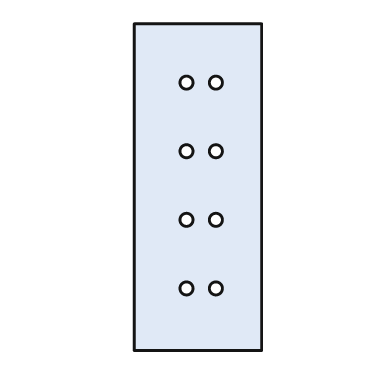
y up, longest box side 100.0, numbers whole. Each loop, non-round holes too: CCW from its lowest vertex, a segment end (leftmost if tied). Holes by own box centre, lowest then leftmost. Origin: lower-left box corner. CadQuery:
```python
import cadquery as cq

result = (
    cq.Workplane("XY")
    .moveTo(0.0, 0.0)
    .lineTo(39.0, 0.0)
    .lineTo(39.0, 100.0)
    .lineTo(0.0, 100.0)
    .close()
    .moveTo(16.0, 19.0)
    .circle(2.0)
    .moveTo(25.0, 19.0)
    .circle(2.0)
    .moveTo(16.0, 40.0)
    .circle(2.0)
    .moveTo(25.0, 40.0)
    .circle(2.0)
    .moveTo(16.0, 61.0)
    .circle(2.0)
    .moveTo(25.0, 61.0)
    .circle(2.0)
    .moveTo(16.0, 82.0)
    .circle(2.0)
    .moveTo(25.0, 82.0)
    .circle(2.0)
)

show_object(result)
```